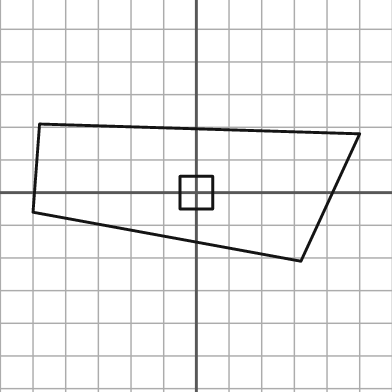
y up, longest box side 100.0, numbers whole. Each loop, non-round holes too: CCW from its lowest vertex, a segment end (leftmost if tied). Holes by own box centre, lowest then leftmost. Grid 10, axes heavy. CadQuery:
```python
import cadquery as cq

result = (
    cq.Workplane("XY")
    .moveTo(32.0, -21.0)
    .lineTo(50.0, 18.0)
    .lineTo(-48.0, 21.0)
    .lineTo(-50.0, -6.0)
    .close()
    .moveTo(-5.0, -5.0)
    .lineTo(5.0, -5.0)
    .lineTo(5.0, 5.0)
    .lineTo(-5.0, 5.0)
    .close()
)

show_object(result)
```